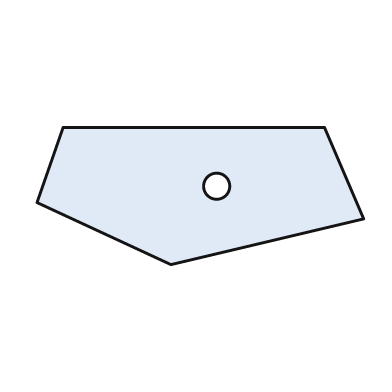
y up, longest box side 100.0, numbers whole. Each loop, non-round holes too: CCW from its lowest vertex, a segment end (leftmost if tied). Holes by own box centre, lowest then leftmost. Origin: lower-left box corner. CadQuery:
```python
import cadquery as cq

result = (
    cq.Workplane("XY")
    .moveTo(41.0, 0.0)
    .lineTo(100.0, 14.0)
    .lineTo(88.0, 42.0)
    .lineTo(8.0, 42.0)
    .lineTo(0.0, 19.0)
    .close()
    .moveTo(55.0, 24.0)
    .circle(4.0)
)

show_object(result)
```